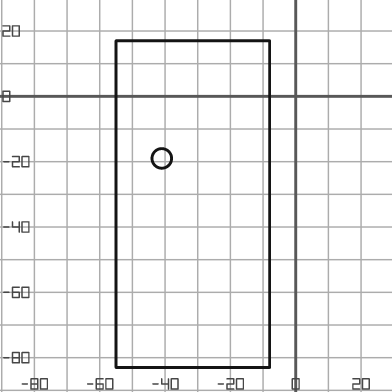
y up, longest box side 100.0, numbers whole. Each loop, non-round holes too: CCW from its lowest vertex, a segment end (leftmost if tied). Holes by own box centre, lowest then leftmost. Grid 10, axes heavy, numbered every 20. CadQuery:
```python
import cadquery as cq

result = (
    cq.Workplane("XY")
    .moveTo(-55.0, -83.0)
    .lineTo(-8.0, -83.0)
    .lineTo(-8.0, 17.0)
    .lineTo(-55.0, 17.0)
    .close()
    .moveTo(-41.0, -19.0)
    .circle(3.0)
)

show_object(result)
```